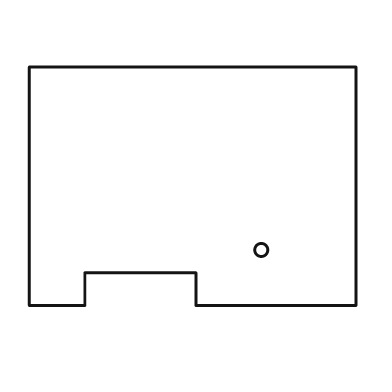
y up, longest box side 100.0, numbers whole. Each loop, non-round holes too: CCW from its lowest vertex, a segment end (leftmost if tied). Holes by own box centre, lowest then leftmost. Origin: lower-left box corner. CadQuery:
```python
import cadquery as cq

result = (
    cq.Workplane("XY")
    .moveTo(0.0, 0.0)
    .lineTo(17.0, 0.0)
    .lineTo(17.0, 10.0)
    .lineTo(51.0, 10.0)
    .lineTo(51.0, 0.0)
    .lineTo(100.0, 0.0)
    .lineTo(100.0, 73.0)
    .lineTo(0.0, 73.0)
    .close()
    .moveTo(71.0, 17.0)
    .circle(2.0)
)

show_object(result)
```